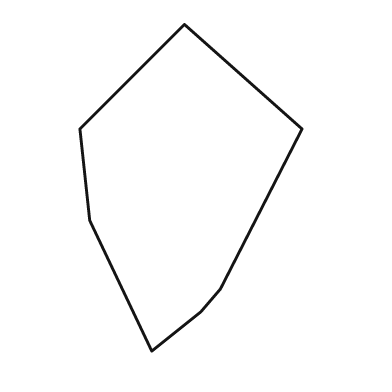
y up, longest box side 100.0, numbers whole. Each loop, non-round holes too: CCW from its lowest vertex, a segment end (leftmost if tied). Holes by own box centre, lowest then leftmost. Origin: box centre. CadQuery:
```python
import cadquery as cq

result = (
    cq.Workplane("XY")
    .moveTo(-12.0, -50.0)
    .lineTo(3.0, -38.0)
    .lineTo(9.0, -31.0)
    .lineTo(34.0, 18.0)
    .lineTo(-2.0, 50.0)
    .lineTo(-34.0, 18.0)
    .lineTo(-31.0, -10.0)
    .close()
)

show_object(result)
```